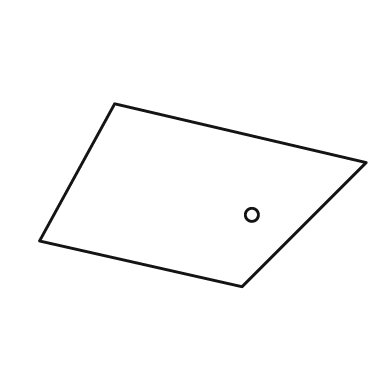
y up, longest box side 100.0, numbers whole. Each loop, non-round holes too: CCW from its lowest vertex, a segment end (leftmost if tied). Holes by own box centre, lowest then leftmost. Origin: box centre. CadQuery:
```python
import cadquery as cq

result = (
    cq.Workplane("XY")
    .moveTo(12.0, -28.0)
    .lineTo(50.0, 10.0)
    .lineTo(-27.0, 28.0)
    .lineTo(-50.0, -14.0)
    .close()
    .moveTo(15.0, -6.0)
    .circle(2.0)
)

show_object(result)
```